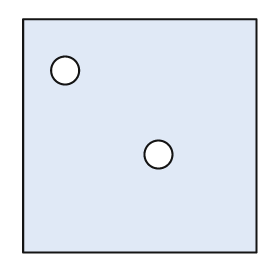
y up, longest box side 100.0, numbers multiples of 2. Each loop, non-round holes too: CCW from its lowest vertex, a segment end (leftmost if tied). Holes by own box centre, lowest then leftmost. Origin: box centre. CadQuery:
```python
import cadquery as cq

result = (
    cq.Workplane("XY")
    .moveTo(-50.0, -50.0)
    .lineTo(50.0, -50.0)
    .lineTo(50.0, 50.0)
    .lineTo(-50.0, 50.0)
    .close()
    .moveTo(8.0, -8.0)
    .circle(6.0)
    .moveTo(-32.0, 28.0)
    .circle(6.0)
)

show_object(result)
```